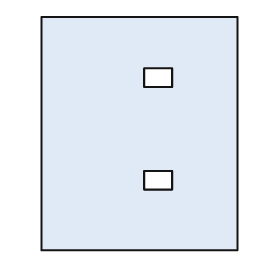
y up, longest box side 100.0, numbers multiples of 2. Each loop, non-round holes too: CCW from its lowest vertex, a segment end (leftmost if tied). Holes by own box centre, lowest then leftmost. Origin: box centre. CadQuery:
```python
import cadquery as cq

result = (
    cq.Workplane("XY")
    .moveTo(-42.0, -50.0)
    .lineTo(42.0, -50.0)
    .lineTo(42.0, 50.0)
    .lineTo(-42.0, 50.0)
    .close()
    .moveTo(2.0, -24.0)
    .lineTo(14.0, -24.0)
    .lineTo(14.0, -16.0)
    .lineTo(2.0, -16.0)
    .close()
    .moveTo(2.0, 20.0)
    .lineTo(14.0, 20.0)
    .lineTo(14.0, 28.0)
    .lineTo(2.0, 28.0)
    .close()
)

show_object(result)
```